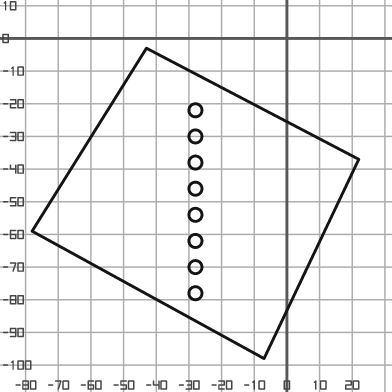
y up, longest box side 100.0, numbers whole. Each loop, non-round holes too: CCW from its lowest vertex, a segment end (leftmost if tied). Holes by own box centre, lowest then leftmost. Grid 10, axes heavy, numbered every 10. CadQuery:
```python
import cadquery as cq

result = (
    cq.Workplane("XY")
    .moveTo(-7.0, -98.0)
    .lineTo(22.0, -37.0)
    .lineTo(-43.0, -3.0)
    .lineTo(-78.0, -59.0)
    .close()
    .moveTo(-28.0, -78.0)
    .circle(2.0)
    .moveTo(-28.0, -70.0)
    .circle(2.0)
    .moveTo(-28.0, -62.0)
    .circle(2.0)
    .moveTo(-28.0, -54.0)
    .circle(2.0)
    .moveTo(-28.0, -46.0)
    .circle(2.0)
    .moveTo(-28.0, -38.0)
    .circle(2.0)
    .moveTo(-28.0, -30.0)
    .circle(2.0)
    .moveTo(-28.0, -22.0)
    .circle(2.0)
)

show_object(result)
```